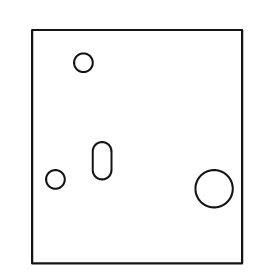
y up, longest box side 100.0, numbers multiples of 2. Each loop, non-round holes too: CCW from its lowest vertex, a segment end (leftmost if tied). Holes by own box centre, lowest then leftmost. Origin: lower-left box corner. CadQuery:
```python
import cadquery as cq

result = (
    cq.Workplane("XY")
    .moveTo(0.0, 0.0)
    .lineTo(90.0, 0.0)
    .lineTo(90.0, 100.0)
    .lineTo(0.0, 100.0)
    .close()
    .moveTo(78.0, 32.0)
    .circle(8.0)
    .moveTo(10.0, 36.0)
    .circle(4.0)
    .moveTo(26.0, 40.0)
    .threePointArc((30.0, 36.0), (34.0, 40.0))
    .lineTo(34.0, 48.0)
    .threePointArc((30.0, 52.0), (26.0, 48.0))
    .close()
    .moveTo(22.0, 86.0)
    .circle(4.0)
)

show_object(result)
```